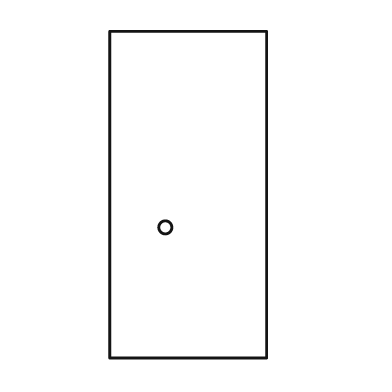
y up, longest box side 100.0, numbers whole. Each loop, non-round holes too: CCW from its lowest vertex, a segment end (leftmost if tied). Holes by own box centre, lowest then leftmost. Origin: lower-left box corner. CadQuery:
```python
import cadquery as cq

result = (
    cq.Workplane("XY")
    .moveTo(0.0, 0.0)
    .lineTo(48.0, 0.0)
    .lineTo(48.0, 100.0)
    .lineTo(0.0, 100.0)
    .close()
    .moveTo(17.0, 40.0)
    .circle(2.0)
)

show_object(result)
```